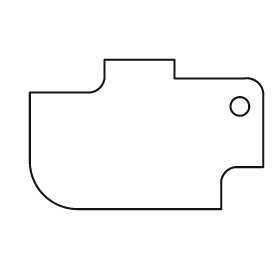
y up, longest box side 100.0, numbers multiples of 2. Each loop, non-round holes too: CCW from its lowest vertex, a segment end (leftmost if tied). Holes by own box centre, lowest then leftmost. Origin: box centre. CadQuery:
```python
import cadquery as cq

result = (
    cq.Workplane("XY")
    .moveTo(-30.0, -32.0)
    .lineTo(32.0, -32.0)
    .lineTo(32.0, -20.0)
    .threePointArc((34.0, -16.0), (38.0, -14.0))
    .lineTo(50.0, -14.0)
    .lineTo(50.0, 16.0)
    .threePointArc((48.0, 22.0), (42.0, 24.0))
    .lineTo(12.0, 24.0)
    .lineTo(12.0, 32.0)
    .lineTo(-18.0, 32.0)
    .lineTo(-18.0, 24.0)
    .threePointArc((-20.0, 20.0), (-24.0, 18.0))
    .lineTo(-50.0, 18.0)
    .lineTo(-50.0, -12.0)
    .threePointArc((-44.0, -26.0), (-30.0, -32.0))
    .close()
    .moveTo(40.0, 12.0)
    .circle(4.0)
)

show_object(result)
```